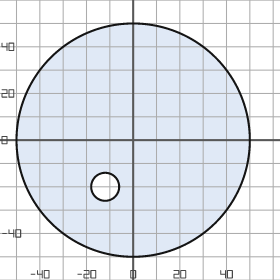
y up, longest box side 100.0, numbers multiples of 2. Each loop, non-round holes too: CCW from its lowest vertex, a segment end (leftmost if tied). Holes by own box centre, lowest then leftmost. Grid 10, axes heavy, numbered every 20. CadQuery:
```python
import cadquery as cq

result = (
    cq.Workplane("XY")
    .moveTo(0.0, 0.0)
    .circle(50.0)
    .moveTo(-12.0, -20.0)
    .circle(6.0)
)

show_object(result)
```